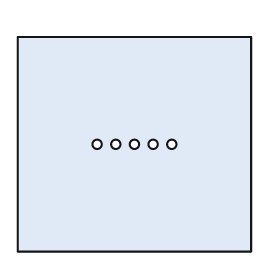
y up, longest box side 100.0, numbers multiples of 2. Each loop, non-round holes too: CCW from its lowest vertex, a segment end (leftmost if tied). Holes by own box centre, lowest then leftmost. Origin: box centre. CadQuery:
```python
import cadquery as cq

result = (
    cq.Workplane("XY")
    .moveTo(-50.0, -46.0)
    .lineTo(50.0, -46.0)
    .lineTo(50.0, 46.0)
    .lineTo(-50.0, 46.0)
    .close()
    .moveTo(-16.0, 0.0)
    .circle(2.0)
    .moveTo(-8.0, 0.0)
    .circle(2.0)
    .moveTo(0.0, 0.0)
    .circle(2.0)
    .moveTo(8.0, 0.0)
    .circle(2.0)
    .moveTo(16.0, 0.0)
    .circle(2.0)
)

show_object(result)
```